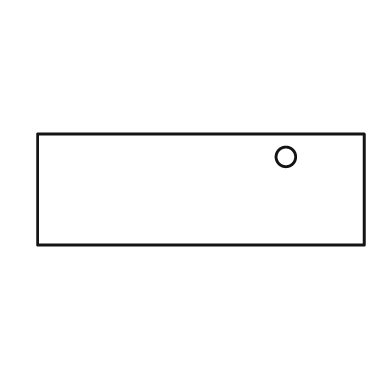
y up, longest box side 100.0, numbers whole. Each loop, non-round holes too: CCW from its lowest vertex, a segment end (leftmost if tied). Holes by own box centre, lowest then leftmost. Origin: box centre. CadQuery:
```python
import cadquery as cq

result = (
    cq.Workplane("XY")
    .moveTo(-50.0, -17.0)
    .lineTo(50.0, -17.0)
    .lineTo(50.0, 17.0)
    .lineTo(-50.0, 17.0)
    .close()
    .moveTo(26.0, 10.0)
    .circle(3.0)
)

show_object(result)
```